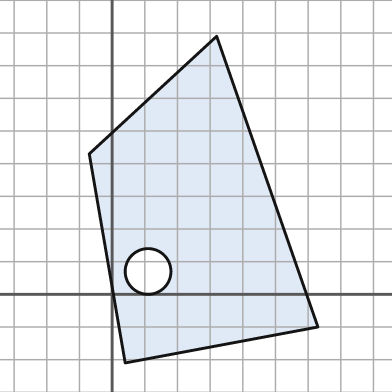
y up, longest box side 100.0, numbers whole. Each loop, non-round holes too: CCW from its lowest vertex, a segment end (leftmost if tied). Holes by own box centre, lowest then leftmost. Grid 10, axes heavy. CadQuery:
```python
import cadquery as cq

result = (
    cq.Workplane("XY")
    .moveTo(4.0, -21.0)
    .lineTo(63.0, -10.0)
    .lineTo(32.0, 79.0)
    .lineTo(-7.0, 43.0)
    .close()
    .moveTo(11.0, 7.0)
    .circle(7.0)
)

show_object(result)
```